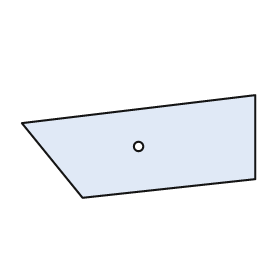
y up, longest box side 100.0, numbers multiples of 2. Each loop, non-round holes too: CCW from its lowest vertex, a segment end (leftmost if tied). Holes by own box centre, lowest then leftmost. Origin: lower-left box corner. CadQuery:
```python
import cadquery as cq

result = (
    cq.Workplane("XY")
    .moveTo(26.0, 0.0)
    .lineTo(100.0, 8.0)
    .lineTo(100.0, 44.0)
    .lineTo(0.0, 32.0)
    .close()
    .moveTo(50.0, 22.0)
    .circle(2.0)
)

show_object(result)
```